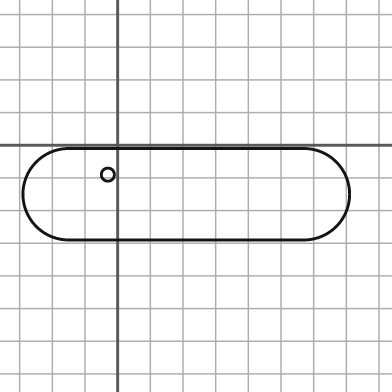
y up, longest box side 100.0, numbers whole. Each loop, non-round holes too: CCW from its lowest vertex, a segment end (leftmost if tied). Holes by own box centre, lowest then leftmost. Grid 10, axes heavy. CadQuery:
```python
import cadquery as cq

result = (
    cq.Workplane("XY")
    .moveTo(-15.0, -29.0)
    .lineTo(57.0, -29.0)
    .threePointArc((71.0, -15.0), (57.0, -1.0))
    .lineTo(-15.0, -1.0)
    .threePointArc((-29.0, -15.0), (-15.0, -29.0))
    .close()
    .moveTo(-3.0, -9.0)
    .circle(2.0)
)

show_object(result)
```